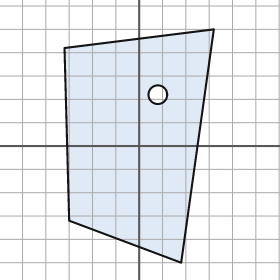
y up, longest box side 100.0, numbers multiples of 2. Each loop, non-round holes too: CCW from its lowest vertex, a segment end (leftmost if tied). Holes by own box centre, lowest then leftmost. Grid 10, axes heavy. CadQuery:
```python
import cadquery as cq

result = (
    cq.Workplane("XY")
    .moveTo(18.0, -50.0)
    .lineTo(32.0, 50.0)
    .lineTo(-32.0, 42.0)
    .lineTo(-30.0, -32.0)
    .close()
    .moveTo(8.0, 22.0)
    .circle(4.0)
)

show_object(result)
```